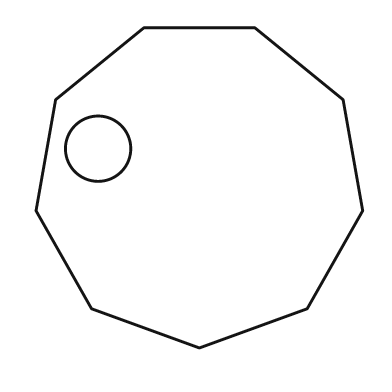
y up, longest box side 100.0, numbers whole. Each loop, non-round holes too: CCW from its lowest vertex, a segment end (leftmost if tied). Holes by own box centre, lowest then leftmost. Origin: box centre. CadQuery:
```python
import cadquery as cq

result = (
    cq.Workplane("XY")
    .moveTo(0.0, -49.0)
    .lineTo(33.0, -37.0)
    .lineTo(50.0, -7.0)
    .lineTo(44.0, 27.0)
    .lineTo(17.0, 49.0)
    .lineTo(-17.0, 49.0)
    .lineTo(-44.0, 27.0)
    .lineTo(-50.0, -7.0)
    .lineTo(-33.0, -37.0)
    .close()
    .moveTo(-31.0, 12.0)
    .circle(10.0)
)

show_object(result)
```